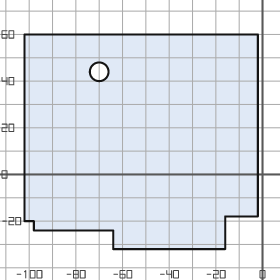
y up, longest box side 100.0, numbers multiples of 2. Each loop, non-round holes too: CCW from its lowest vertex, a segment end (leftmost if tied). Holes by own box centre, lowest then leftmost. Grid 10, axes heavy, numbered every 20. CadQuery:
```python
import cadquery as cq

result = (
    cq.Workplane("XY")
    .moveTo(-64.0, -32.0)
    .lineTo(-16.0, -32.0)
    .lineTo(-16.0, -18.0)
    .lineTo(-2.0, -18.0)
    .lineTo(-2.0, 60.0)
    .lineTo(-102.0, 60.0)
    .lineTo(-102.0, -20.0)
    .lineTo(-98.0, -20.0)
    .lineTo(-98.0, -24.0)
    .lineTo(-64.0, -24.0)
    .close()
    .moveTo(-70.0, 44.0)
    .circle(4.0)
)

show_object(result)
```